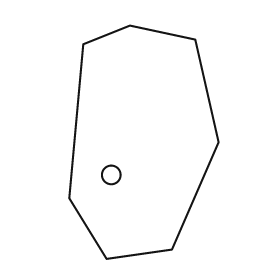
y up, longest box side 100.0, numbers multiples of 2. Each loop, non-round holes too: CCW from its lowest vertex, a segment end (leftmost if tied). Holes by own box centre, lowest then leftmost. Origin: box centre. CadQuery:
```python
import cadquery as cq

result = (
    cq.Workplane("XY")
    .moveTo(-16.0, -50.0)
    .lineTo(12.0, -46.0)
    .lineTo(32.0, 0.0)
    .lineTo(22.0, 44.0)
    .lineTo(-6.0, 50.0)
    .lineTo(-26.0, 42.0)
    .lineTo(-32.0, -24.0)
    .close()
    .moveTo(-14.0, -14.0)
    .circle(4.0)
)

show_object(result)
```